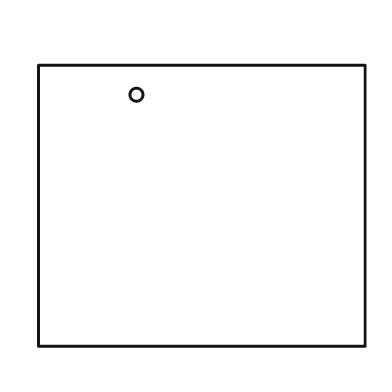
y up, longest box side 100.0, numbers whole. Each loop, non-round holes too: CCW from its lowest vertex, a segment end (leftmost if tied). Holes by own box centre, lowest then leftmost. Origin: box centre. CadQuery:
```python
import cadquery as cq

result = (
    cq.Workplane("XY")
    .moveTo(-50.0, -43.0)
    .lineTo(50.0, -43.0)
    .lineTo(50.0, 43.0)
    .lineTo(-50.0, 43.0)
    .close()
    .moveTo(-20.0, 34.0)
    .circle(2.0)
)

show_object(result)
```